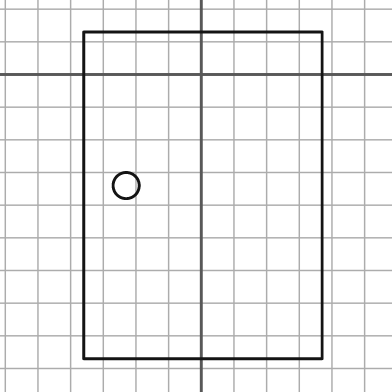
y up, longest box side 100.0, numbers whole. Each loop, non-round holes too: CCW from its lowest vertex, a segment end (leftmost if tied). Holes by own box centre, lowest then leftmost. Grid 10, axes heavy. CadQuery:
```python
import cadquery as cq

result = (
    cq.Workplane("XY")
    .moveTo(-36.0, -87.0)
    .lineTo(37.0, -87.0)
    .lineTo(37.0, 13.0)
    .lineTo(-36.0, 13.0)
    .close()
    .moveTo(-23.0, -34.0)
    .circle(4.0)
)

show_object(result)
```